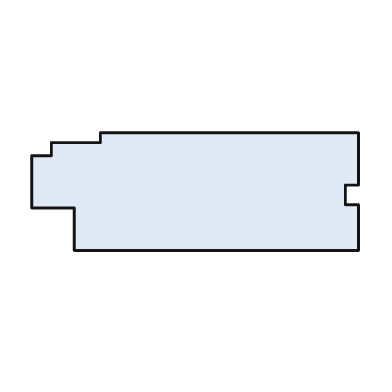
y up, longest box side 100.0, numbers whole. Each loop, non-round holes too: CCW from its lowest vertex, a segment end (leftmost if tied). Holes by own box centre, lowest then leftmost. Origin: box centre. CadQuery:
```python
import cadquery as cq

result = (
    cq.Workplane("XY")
    .moveTo(-37.0, -18.0)
    .lineTo(50.0, -18.0)
    .lineTo(50.0, -4.0)
    .lineTo(46.0, -4.0)
    .lineTo(46.0, 2.0)
    .lineTo(50.0, 2.0)
    .lineTo(50.0, 18.0)
    .lineTo(-29.0, 18.0)
    .lineTo(-29.0, 15.0)
    .lineTo(-44.0, 15.0)
    .lineTo(-44.0, 11.0)
    .lineTo(-50.0, 11.0)
    .lineTo(-50.0, -5.0)
    .lineTo(-37.0, -5.0)
    .close()
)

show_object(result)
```